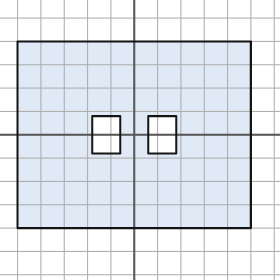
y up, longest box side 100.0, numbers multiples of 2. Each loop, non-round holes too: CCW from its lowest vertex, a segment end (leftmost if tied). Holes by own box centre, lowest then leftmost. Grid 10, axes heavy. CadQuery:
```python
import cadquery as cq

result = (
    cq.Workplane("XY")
    .moveTo(-50.0, -40.0)
    .lineTo(50.0, -40.0)
    .lineTo(50.0, 40.0)
    .lineTo(-50.0, 40.0)
    .close()
    .moveTo(-18.0, -8.0)
    .lineTo(-6.0, -8.0)
    .lineTo(-6.0, 8.0)
    .lineTo(-18.0, 8.0)
    .close()
    .moveTo(6.0, -8.0)
    .lineTo(18.0, -8.0)
    .lineTo(18.0, 8.0)
    .lineTo(6.0, 8.0)
    .close()
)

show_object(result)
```